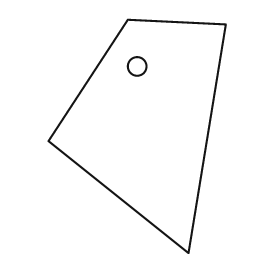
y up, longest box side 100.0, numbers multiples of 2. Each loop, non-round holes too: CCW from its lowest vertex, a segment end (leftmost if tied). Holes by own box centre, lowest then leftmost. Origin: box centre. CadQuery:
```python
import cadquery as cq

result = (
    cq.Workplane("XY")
    .moveTo(22.0, -50.0)
    .lineTo(38.0, 48.0)
    .lineTo(-4.0, 50.0)
    .lineTo(-38.0, -2.0)
    .close()
    .moveTo(0.0, 30.0)
    .circle(4.0)
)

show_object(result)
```